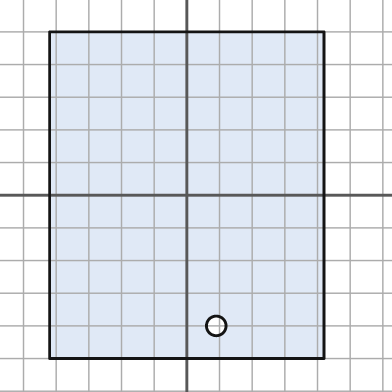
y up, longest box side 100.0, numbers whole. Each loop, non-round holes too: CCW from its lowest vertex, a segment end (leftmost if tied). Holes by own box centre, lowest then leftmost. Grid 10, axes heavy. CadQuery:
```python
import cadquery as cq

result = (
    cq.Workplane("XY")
    .moveTo(-42.0, -50.0)
    .lineTo(42.0, -50.0)
    .lineTo(42.0, 50.0)
    .lineTo(-42.0, 50.0)
    .close()
    .moveTo(9.0, -40.0)
    .circle(3.0)
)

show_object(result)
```